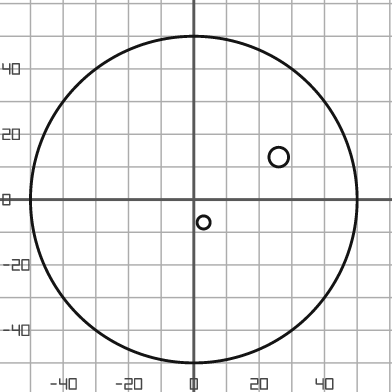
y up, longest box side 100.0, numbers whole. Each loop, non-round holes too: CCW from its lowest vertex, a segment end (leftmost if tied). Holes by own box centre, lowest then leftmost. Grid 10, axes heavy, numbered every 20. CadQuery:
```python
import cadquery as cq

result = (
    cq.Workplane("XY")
    .moveTo(0.0, 0.0)
    .circle(50.0)
    .moveTo(3.0, -7.0)
    .circle(2.0)
    .moveTo(26.0, 13.0)
    .circle(3.0)
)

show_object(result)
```